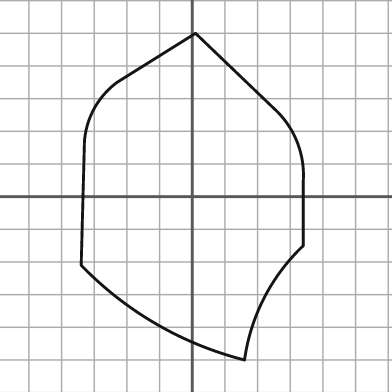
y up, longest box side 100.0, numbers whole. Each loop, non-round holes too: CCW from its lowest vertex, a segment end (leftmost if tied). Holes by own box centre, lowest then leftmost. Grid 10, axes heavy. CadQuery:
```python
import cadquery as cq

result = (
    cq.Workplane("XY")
    .moveTo(16.0, -50.0)
    .threePointArc((22.0, -31.0), (34.0, -15.0))
    .lineTo(34.0, 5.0)
    .threePointArc((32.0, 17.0), (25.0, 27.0))
    .lineTo(1.0, 50.0)
    .lineTo(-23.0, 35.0)
    .threePointArc((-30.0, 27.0), (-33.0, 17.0))
    .lineTo(-34.0, -21.0)
    .threePointArc((-11.0, -39.0), (16.0, -50.0))
    .close()
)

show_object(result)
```